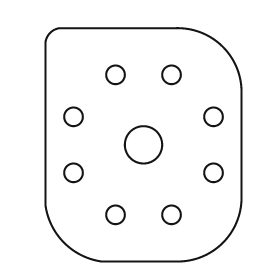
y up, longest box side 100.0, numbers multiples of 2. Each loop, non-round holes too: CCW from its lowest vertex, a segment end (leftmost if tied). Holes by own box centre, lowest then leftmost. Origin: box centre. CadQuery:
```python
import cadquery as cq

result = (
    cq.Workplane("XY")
    .moveTo(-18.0, -50.0)
    .lineTo(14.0, -50.0)
    .threePointArc((34.0, -42.0), (42.0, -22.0))
    .lineTo(42.0, 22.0)
    .threePointArc((34.0, 42.0), (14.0, 50.0))
    .lineTo(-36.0, 50.0)
    .threePointArc((-40.0, 48.0), (-42.0, 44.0))
    .lineTo(-42.0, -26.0)
    .threePointArc((-34.0, -42.0), (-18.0, -50.0))
    .close()
    .moveTo(-12.0, -30.0)
    .circle(4.0)
    .moveTo(12.0, -30.0)
    .circle(4.0)
    .moveTo(-30.0, -12.0)
    .circle(4.0)
    .moveTo(30.0, -12.0)
    .circle(4.0)
    .moveTo(0.0, 0.0)
    .circle(8.0)
    .moveTo(-30.0, 12.0)
    .circle(4.0)
    .moveTo(30.0, 12.0)
    .circle(4.0)
    .moveTo(-12.0, 30.0)
    .circle(4.0)
    .moveTo(12.0, 30.0)
    .circle(4.0)
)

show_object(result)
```